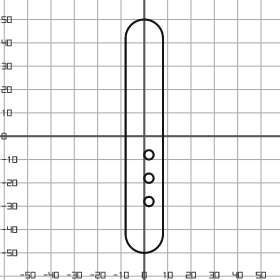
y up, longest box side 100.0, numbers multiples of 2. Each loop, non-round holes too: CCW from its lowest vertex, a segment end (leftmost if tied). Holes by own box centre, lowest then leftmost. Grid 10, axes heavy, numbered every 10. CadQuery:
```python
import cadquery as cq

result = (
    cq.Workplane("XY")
    .moveTo(-8.0, -42.0)
    .threePointArc((0.0, -50.0), (8.0, -42.0))
    .lineTo(8.0, 42.0)
    .threePointArc((0.0, 50.0), (-8.0, 42.0))
    .close()
    .moveTo(2.0, -28.0)
    .circle(2.0)
    .moveTo(2.0, -18.0)
    .circle(2.0)
    .moveTo(2.0, -8.0)
    .circle(2.0)
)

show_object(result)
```